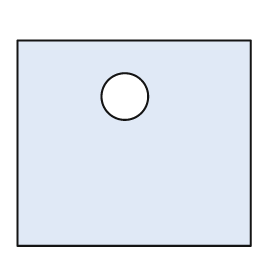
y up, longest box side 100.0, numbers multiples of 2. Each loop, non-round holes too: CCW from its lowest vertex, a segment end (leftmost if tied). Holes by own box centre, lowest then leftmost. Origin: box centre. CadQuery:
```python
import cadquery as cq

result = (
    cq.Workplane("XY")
    .moveTo(-50.0, -44.0)
    .lineTo(50.0, -44.0)
    .lineTo(50.0, 44.0)
    .lineTo(-50.0, 44.0)
    .close()
    .moveTo(-4.0, 20.0)
    .circle(10.0)
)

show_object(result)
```